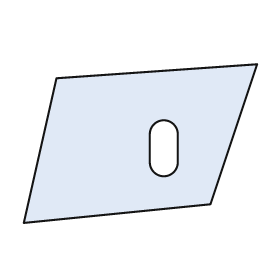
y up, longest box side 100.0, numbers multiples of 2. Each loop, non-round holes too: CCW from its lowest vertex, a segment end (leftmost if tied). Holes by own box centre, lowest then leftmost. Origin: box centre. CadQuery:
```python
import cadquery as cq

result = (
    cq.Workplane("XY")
    .moveTo(-50.0, -34.0)
    .lineTo(30.0, -26.0)
    .lineTo(50.0, 34.0)
    .lineTo(-36.0, 28.0)
    .close()
    .moveTo(4.0, -8.0)
    .threePointArc((10.0, -14.0), (16.0, -8.0))
    .lineTo(16.0, 4.0)
    .threePointArc((10.0, 10.0), (4.0, 4.0))
    .close()
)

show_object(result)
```